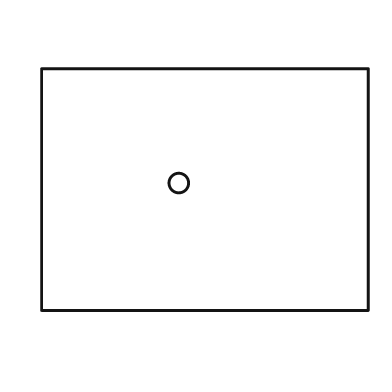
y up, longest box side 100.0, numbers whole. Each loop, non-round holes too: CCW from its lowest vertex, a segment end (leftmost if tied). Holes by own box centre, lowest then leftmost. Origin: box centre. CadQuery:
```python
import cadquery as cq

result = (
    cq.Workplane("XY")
    .moveTo(-50.0, -37.0)
    .lineTo(50.0, -37.0)
    .lineTo(50.0, 37.0)
    .lineTo(-50.0, 37.0)
    .close()
    .moveTo(-8.0, 2.0)
    .circle(3.0)
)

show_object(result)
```